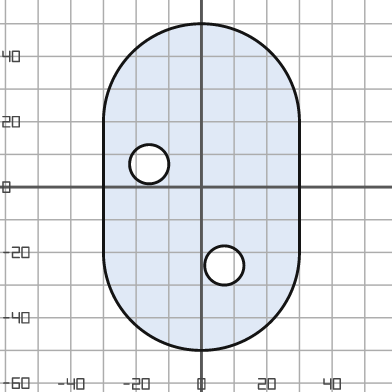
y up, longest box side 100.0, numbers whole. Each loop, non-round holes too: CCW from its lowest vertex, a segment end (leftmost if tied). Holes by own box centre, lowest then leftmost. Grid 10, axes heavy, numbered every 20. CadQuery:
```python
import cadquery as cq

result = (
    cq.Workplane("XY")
    .moveTo(-30.0, -20.0)
    .threePointArc((0.0, -50.0), (30.0, -20.0))
    .lineTo(30.0, 20.0)
    .threePointArc((0.0, 50.0), (-30.0, 20.0))
    .close()
    .moveTo(7.0, -24.0)
    .circle(6.0)
    .moveTo(-16.0, 7.0)
    .circle(6.0)
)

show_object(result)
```